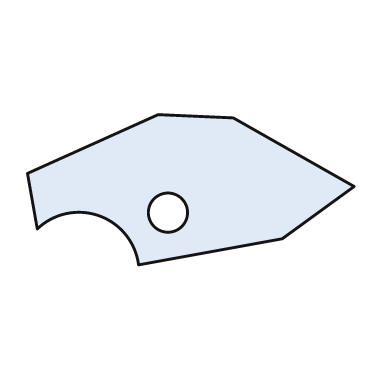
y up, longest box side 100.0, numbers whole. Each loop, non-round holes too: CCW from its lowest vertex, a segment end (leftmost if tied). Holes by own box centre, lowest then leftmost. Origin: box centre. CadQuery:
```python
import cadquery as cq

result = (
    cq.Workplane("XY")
    .moveTo(-16.0, -23.0)
    .lineTo(28.0, -15.0)
    .lineTo(50.0, 1.0)
    .lineTo(13.0, 22.0)
    .lineTo(-10.0, 23.0)
    .lineTo(-50.0, 5.0)
    .lineTo(-47.0, -12.0)
    .threePointArc((-28.0, -8.0), (-16.0, -23.0))
    .close()
    .moveTo(-7.0, -7.0)
    .circle(6.0)
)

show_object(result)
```